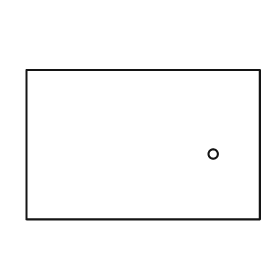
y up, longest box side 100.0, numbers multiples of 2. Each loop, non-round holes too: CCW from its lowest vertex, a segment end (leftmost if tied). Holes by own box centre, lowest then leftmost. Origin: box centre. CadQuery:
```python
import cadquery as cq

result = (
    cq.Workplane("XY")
    .moveTo(-50.0, -32.0)
    .lineTo(50.0, -32.0)
    .lineTo(50.0, 32.0)
    .lineTo(-50.0, 32.0)
    .close()
    .moveTo(30.0, -4.0)
    .circle(2.0)
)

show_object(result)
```